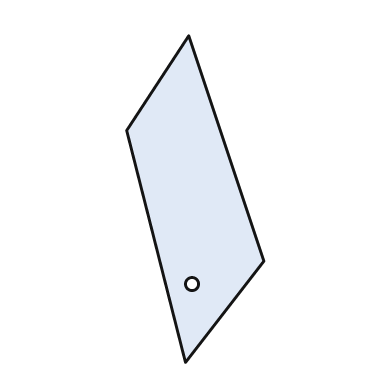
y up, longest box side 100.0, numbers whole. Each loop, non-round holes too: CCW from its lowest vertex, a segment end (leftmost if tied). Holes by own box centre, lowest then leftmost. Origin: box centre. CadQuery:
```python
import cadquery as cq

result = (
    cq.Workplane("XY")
    .moveTo(-3.0, -50.0)
    .lineTo(21.0, -19.0)
    .lineTo(-2.0, 50.0)
    .lineTo(-21.0, 21.0)
    .close()
    .moveTo(-1.0, -26.0)
    .circle(2.0)
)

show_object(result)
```